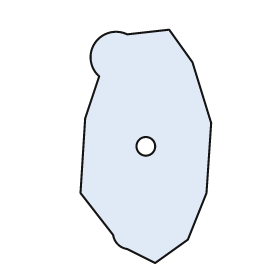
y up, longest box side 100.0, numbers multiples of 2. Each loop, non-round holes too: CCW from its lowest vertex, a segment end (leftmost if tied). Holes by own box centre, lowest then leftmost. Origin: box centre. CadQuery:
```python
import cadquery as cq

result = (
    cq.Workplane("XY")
    .moveTo(4.0, -50.0)
    .lineTo(18.0, -40.0)
    .lineTo(26.0, -20.0)
    .lineTo(28.0, 10.0)
    .lineTo(20.0, 36.0)
    .lineTo(10.0, 50.0)
    .lineTo(-8.0, 48.0)
    .threePointArc((-22.0, 44.0), (-20.0, 30.0))
    .lineTo(-26.0, 12.0)
    .lineTo(-28.0, -20.0)
    .lineTo(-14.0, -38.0)
    .threePointArc((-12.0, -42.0), (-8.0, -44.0))
    .close()
    .moveTo(0.0, 0.0)
    .circle(4.0)
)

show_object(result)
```